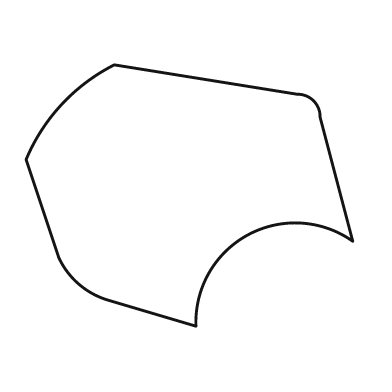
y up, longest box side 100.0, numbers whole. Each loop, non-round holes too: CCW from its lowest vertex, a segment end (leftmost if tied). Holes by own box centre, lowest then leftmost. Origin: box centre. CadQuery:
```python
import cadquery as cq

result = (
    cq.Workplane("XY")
    .moveTo(2.0, -40.0)
    .threePointArc((18.0, -12.0), (50.0, -14.0))
    .lineTo(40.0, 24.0)
    .threePointArc((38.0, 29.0), (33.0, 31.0))
    .lineTo(-23.0, 40.0)
    .threePointArc((-39.0, 28.0), (-50.0, 11.0))
    .lineTo(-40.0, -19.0)
    .threePointArc((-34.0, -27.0), (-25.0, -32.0))
    .close()
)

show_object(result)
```